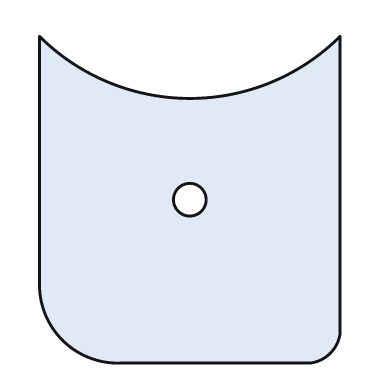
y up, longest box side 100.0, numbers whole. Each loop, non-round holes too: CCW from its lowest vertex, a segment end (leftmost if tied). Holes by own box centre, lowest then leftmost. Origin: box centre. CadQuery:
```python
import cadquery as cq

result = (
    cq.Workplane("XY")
    .moveTo(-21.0, -50.0)
    .lineTo(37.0, -50.0)
    .threePointArc((43.0, -47.0), (46.0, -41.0))
    .lineTo(46.0, 50.0)
    .threePointArc((0.0, 31.0), (-46.0, 50.0))
    .lineTo(-46.0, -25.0)
    .threePointArc((-39.0, -43.0), (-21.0, -50.0))
    .close()
    .moveTo(0.0, 0.0)
    .circle(5.0)
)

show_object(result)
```